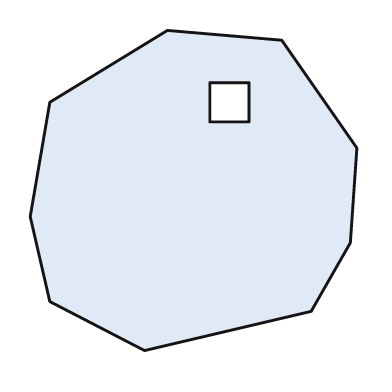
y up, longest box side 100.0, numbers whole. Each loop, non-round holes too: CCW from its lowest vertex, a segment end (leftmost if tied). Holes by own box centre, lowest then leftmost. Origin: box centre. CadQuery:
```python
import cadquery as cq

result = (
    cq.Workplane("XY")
    .moveTo(-15.0, -49.0)
    .lineTo(36.0, -37.0)
    .lineTo(48.0, -16.0)
    .lineTo(50.0, 13.0)
    .lineTo(27.0, 46.0)
    .lineTo(-8.0, 49.0)
    .lineTo(-44.0, 27.0)
    .lineTo(-50.0, -8.0)
    .lineTo(-44.0, -34.0)
    .close()
    .moveTo(5.0, 21.0)
    .lineTo(17.0, 21.0)
    .lineTo(17.0, 33.0)
    .lineTo(5.0, 33.0)
    .close()
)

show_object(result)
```